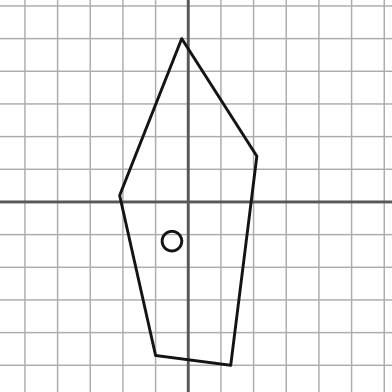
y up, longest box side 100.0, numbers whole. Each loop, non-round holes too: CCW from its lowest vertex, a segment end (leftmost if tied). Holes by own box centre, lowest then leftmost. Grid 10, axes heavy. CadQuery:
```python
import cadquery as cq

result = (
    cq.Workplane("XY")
    .moveTo(13.0, -50.0)
    .lineTo(21.0, 14.0)
    .lineTo(-2.0, 50.0)
    .lineTo(-21.0, 2.0)
    .lineTo(-10.0, -47.0)
    .close()
    .moveTo(-5.0, -12.0)
    .circle(3.0)
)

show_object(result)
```